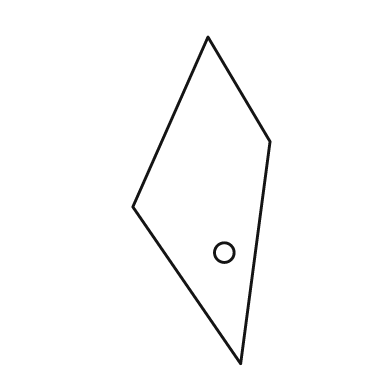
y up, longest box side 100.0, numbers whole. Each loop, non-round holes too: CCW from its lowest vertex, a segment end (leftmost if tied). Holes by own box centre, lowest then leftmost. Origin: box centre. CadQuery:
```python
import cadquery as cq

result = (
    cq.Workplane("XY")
    .moveTo(12.0, -50.0)
    .lineTo(21.0, 18.0)
    .lineTo(2.0, 50.0)
    .lineTo(-21.0, -2.0)
    .close()
    .moveTo(7.0, -16.0)
    .circle(3.0)
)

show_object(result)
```